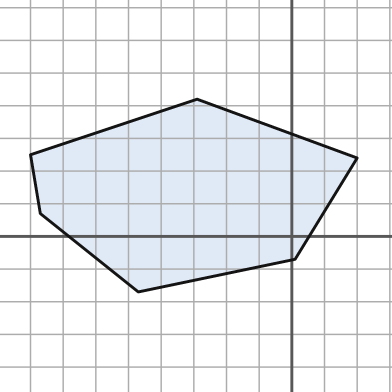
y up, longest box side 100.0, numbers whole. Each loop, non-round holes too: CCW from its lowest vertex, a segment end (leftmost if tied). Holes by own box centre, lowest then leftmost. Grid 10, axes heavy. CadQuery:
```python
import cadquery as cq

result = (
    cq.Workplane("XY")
    .moveTo(-47.0, -17.0)
    .lineTo(1.0, -7.0)
    .lineTo(20.0, 24.0)
    .lineTo(-29.0, 42.0)
    .lineTo(-80.0, 25.0)
    .lineTo(-77.0, 7.0)
    .close()
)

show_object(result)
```